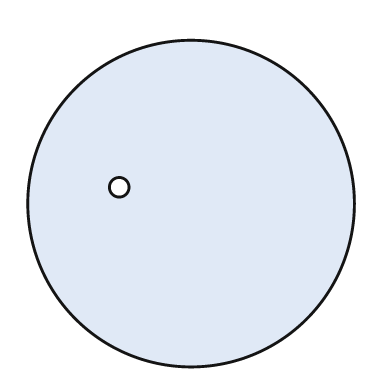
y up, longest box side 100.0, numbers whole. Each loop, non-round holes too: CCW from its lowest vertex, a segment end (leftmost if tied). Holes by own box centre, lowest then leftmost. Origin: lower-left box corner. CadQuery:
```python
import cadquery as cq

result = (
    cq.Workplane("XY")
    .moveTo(50.0, 50.0)
    .circle(50.0)
    .moveTo(28.0, 55.0)
    .circle(3.0)
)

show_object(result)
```